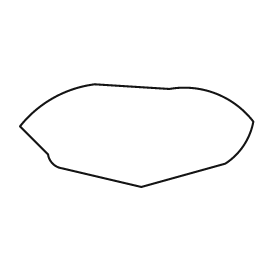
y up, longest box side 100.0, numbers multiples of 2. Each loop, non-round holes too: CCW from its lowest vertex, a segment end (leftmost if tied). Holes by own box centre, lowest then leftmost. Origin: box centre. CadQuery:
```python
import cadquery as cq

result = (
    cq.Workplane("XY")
    .moveTo(2.0, -22.0)
    .lineTo(38.0, -12.0)
    .threePointArc((46.0, -4.0), (50.0, 6.0))
    .threePointArc((34.0, 18.0), (14.0, 20.0))
    .lineTo(-18.0, 22.0)
    .threePointArc((-36.0, 16.0), (-50.0, 4.0))
    .lineTo(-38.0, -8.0)
    .threePointArc((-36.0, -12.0), (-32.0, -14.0))
    .close()
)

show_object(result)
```